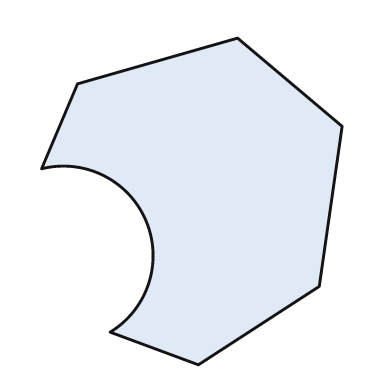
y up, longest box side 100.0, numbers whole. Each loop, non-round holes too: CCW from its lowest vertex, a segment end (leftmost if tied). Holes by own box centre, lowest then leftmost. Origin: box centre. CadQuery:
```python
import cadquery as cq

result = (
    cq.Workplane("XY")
    .moveTo(2.0, -50.0)
    .lineTo(39.0, -26.0)
    .lineTo(46.0, 23.0)
    .lineTo(14.0, 50.0)
    .lineTo(-35.0, 36.0)
    .lineTo(-46.0, 10.0)
    .threePointArc((-14.0, -6.0), (-25.0, -40.0))
    .close()
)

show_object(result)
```